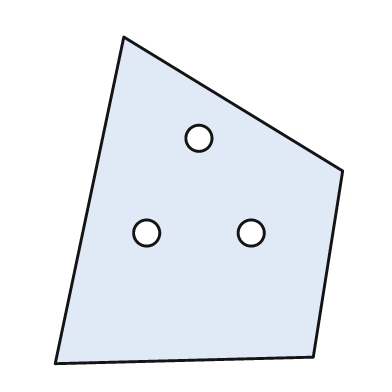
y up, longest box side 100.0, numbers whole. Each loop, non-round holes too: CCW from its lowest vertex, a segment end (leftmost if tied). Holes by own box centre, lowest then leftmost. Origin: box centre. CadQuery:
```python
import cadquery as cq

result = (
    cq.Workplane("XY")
    .moveTo(-44.0, -50.0)
    .lineTo(35.0, -48.0)
    .lineTo(44.0, 9.0)
    .lineTo(-23.0, 50.0)
    .close()
    .moveTo(-16.0, -10.0)
    .circle(4.0)
    .moveTo(16.0, -10.0)
    .circle(4.0)
    .moveTo(0.0, 19.0)
    .circle(4.0)
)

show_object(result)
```